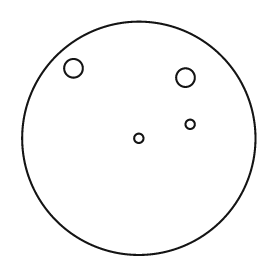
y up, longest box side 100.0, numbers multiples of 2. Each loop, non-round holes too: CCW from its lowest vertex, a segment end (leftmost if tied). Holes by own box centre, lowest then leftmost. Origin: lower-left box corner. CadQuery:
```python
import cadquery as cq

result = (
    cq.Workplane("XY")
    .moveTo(50.0, 50.0)
    .circle(50.0)
    .moveTo(50.0, 50.0)
    .circle(2.0)
    .moveTo(72.0, 56.0)
    .circle(2.0)
    .moveTo(70.0, 76.0)
    .circle(4.0)
    .moveTo(22.0, 80.0)
    .circle(4.0)
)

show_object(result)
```